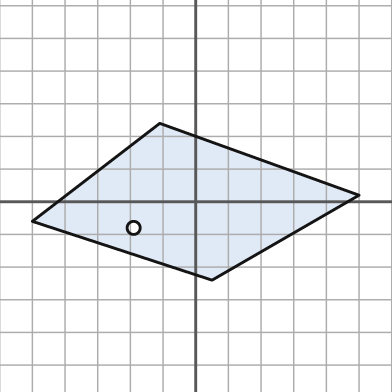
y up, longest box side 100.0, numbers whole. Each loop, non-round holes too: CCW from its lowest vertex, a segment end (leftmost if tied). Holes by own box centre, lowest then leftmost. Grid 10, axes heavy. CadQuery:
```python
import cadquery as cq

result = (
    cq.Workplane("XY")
    .moveTo(5.0, -24.0)
    .lineTo(50.0, 2.0)
    .lineTo(-11.0, 24.0)
    .lineTo(-50.0, -6.0)
    .close()
    .moveTo(-19.0, -8.0)
    .circle(2.0)
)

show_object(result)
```